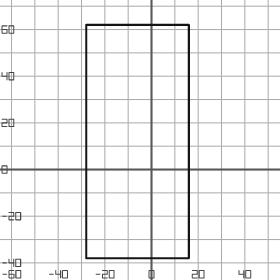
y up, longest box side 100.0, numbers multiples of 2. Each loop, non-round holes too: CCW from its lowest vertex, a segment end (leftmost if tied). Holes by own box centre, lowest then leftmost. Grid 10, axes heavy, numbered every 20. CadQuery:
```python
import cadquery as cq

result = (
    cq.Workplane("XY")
    .moveTo(-28.0, -38.0)
    .lineTo(16.0, -38.0)
    .lineTo(16.0, 62.0)
    .lineTo(-28.0, 62.0)
    .close()
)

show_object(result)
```